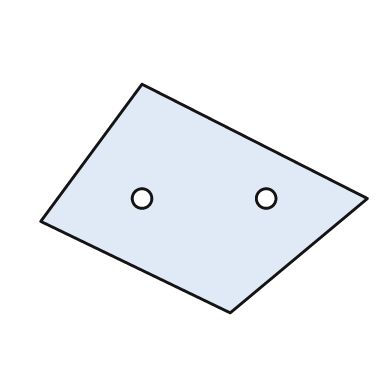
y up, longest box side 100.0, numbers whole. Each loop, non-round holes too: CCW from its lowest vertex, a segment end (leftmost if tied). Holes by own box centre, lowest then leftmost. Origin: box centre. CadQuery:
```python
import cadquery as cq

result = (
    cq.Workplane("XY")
    .moveTo(8.0, -35.0)
    .lineTo(50.0, 0.0)
    .lineTo(-19.0, 35.0)
    .lineTo(-50.0, -7.0)
    .close()
    .moveTo(-19.0, 0.0)
    .circle(3.0)
    .moveTo(19.0, 0.0)
    .circle(3.0)
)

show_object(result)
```